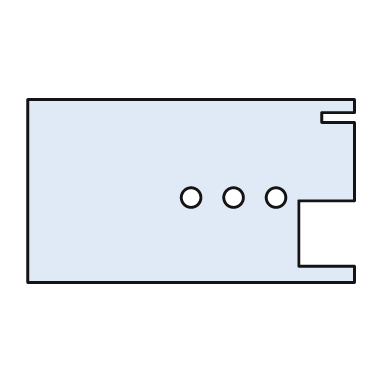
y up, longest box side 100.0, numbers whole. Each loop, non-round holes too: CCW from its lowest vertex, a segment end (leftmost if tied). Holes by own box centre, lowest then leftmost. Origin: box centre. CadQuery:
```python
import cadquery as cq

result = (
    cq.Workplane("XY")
    .moveTo(-50.0, -28.0)
    .lineTo(50.0, -28.0)
    .lineTo(50.0, -23.0)
    .lineTo(33.0, -23.0)
    .lineTo(33.0, -3.0)
    .lineTo(50.0, -3.0)
    .lineTo(50.0, 21.0)
    .lineTo(40.0, 21.0)
    .lineTo(40.0, 24.0)
    .lineTo(50.0, 24.0)
    .lineTo(50.0, 28.0)
    .lineTo(-50.0, 28.0)
    .close()
    .moveTo(0.0, -2.0)
    .circle(3.0)
    .moveTo(13.0, -2.0)
    .circle(3.0)
    .moveTo(26.0, -2.0)
    .circle(3.0)
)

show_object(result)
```